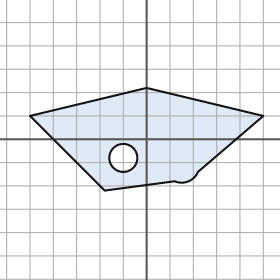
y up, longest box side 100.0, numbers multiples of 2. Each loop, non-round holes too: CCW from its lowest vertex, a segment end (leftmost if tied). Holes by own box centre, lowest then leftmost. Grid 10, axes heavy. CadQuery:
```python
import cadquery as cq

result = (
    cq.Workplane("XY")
    .moveTo(-18.0, -22.0)
    .lineTo(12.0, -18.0)
    .threePointArc((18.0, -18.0), (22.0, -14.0))
    .lineTo(50.0, 10.0)
    .lineTo(0.0, 22.0)
    .lineTo(-50.0, 10.0)
    .close()
    .moveTo(-10.0, -8.0)
    .circle(6.0)
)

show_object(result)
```